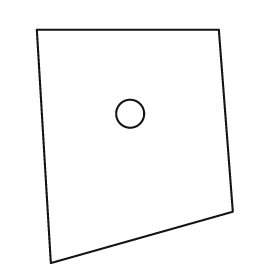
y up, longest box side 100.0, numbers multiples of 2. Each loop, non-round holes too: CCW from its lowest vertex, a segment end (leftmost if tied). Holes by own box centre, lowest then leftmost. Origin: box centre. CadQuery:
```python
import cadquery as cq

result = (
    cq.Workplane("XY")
    .moveTo(-36.0, -50.0)
    .lineTo(42.0, -28.0)
    .lineTo(36.0, 50.0)
    .lineTo(-42.0, 50.0)
    .close()
    .moveTo(-2.0, 14.0)
    .circle(6.0)
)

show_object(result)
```